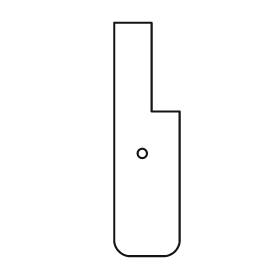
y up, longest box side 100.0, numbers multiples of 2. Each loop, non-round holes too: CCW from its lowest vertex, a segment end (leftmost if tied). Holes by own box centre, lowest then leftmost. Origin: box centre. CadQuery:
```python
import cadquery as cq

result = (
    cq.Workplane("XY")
    .moveTo(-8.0, -50.0)
    .lineTo(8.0, -50.0)
    .threePointArc((12.0, -48.0), (14.0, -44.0))
    .lineTo(14.0, 12.0)
    .lineTo(2.0, 12.0)
    .lineTo(2.0, 50.0)
    .lineTo(-14.0, 50.0)
    .lineTo(-14.0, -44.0)
    .threePointArc((-12.0, -48.0), (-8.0, -50.0))
    .close()
    .moveTo(-2.0, -6.0)
    .circle(2.0)
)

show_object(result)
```